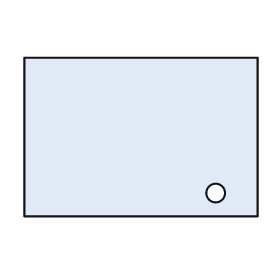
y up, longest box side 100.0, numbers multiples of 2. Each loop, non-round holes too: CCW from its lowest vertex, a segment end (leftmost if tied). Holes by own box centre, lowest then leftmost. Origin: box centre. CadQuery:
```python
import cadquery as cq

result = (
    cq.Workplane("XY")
    .moveTo(-50.0, -34.0)
    .lineTo(50.0, -34.0)
    .lineTo(50.0, 34.0)
    .lineTo(-50.0, 34.0)
    .close()
    .moveTo(32.0, -24.0)
    .circle(4.0)
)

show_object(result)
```